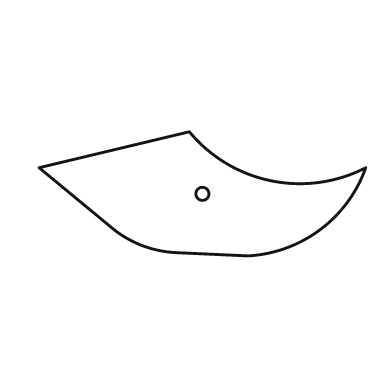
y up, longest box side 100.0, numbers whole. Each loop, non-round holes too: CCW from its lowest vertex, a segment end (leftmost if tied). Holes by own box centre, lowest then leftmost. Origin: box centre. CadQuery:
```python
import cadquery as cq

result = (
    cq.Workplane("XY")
    .moveTo(14.0, -19.0)
    .threePointArc((36.0, -11.0), (50.0, 8.0))
    .threePointArc((21.0, 4.0), (-4.0, 19.0))
    .lineTo(-50.0, 8.0)
    .lineTo(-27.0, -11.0)
    .threePointArc((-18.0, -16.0), (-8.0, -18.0))
    .close()
    .moveTo(0.0, 0.0)
    .circle(2.0)
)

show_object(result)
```